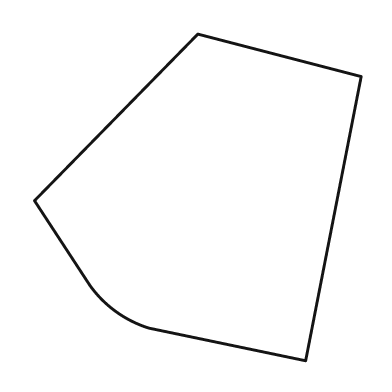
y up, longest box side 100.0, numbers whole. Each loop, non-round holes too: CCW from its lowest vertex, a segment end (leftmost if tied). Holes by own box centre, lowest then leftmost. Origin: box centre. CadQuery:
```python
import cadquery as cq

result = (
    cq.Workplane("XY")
    .moveTo(33.0, -50.0)
    .lineTo(50.0, 37.0)
    .lineTo(0.0, 50.0)
    .lineTo(-50.0, -1.0)
    .lineTo(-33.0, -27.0)
    .threePointArc((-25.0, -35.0), (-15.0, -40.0))
    .close()
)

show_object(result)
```